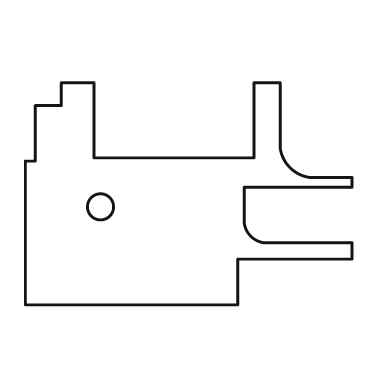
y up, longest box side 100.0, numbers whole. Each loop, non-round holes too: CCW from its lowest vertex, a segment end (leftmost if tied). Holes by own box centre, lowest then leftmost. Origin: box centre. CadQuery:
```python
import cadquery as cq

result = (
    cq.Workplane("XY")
    .moveTo(-50.0, -34.0)
    .lineTo(15.0, -34.0)
    .lineTo(15.0, -20.0)
    .lineTo(50.0, -20.0)
    .lineTo(50.0, -15.0)
    .lineTo(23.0, -15.0)
    .threePointArc((19.0, -13.0), (17.0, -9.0))
    .lineTo(17.0, 2.0)
    .lineTo(50.0, 2.0)
    .lineTo(50.0, 5.0)
    .lineTo(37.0, 5.0)
    .threePointArc((31.0, 8.0), (28.0, 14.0))
    .lineTo(28.0, 34.0)
    .lineTo(20.0, 34.0)
    .lineTo(20.0, 11.0)
    .lineTo(-29.0, 11.0)
    .lineTo(-29.0, 34.0)
    .lineTo(-39.0, 34.0)
    .lineTo(-39.0, 27.0)
    .lineTo(-47.0, 27.0)
    .lineTo(-47.0, 10.0)
    .lineTo(-50.0, 10.0)
    .close()
    .moveTo(-27.0, -4.0)
    .circle(4.0)
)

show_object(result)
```